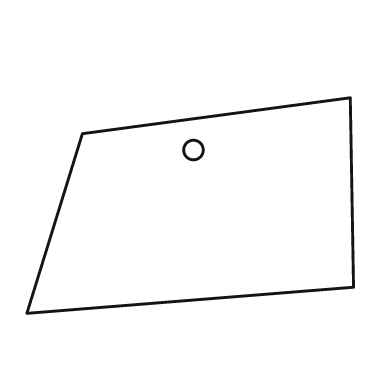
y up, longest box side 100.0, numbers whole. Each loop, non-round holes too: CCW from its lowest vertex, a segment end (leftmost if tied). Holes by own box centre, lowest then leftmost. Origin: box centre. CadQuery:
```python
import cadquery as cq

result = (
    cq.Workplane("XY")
    .moveTo(-50.0, -33.0)
    .lineTo(50.0, -25.0)
    .lineTo(49.0, 33.0)
    .lineTo(-33.0, 22.0)
    .close()
    .moveTo(1.0, 17.0)
    .circle(3.0)
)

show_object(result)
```